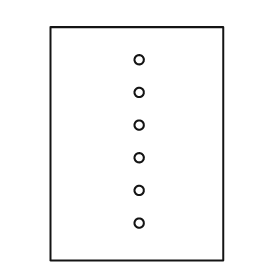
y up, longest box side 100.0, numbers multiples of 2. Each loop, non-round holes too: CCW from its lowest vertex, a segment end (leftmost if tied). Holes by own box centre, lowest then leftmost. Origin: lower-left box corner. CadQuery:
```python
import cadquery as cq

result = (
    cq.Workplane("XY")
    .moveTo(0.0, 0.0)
    .lineTo(74.0, 0.0)
    .lineTo(74.0, 100.0)
    .lineTo(0.0, 100.0)
    .close()
    .moveTo(38.0, 16.0)
    .circle(2.0)
    .moveTo(38.0, 30.0)
    .circle(2.0)
    .moveTo(38.0, 44.0)
    .circle(2.0)
    .moveTo(38.0, 58.0)
    .circle(2.0)
    .moveTo(38.0, 72.0)
    .circle(2.0)
    .moveTo(38.0, 86.0)
    .circle(2.0)
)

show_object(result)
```